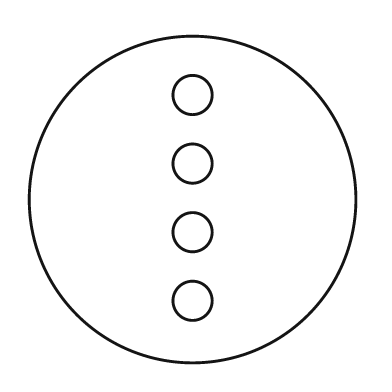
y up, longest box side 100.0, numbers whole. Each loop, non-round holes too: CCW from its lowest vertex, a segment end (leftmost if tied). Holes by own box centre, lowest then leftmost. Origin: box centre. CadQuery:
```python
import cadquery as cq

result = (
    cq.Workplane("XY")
    .moveTo(0.0, 0.0)
    .circle(50.0)
    .moveTo(0.0, -31.0)
    .circle(6.0)
    .moveTo(0.0, -10.0)
    .circle(6.0)
    .moveTo(0.0, 11.0)
    .circle(6.0)
    .moveTo(0.0, 32.0)
    .circle(6.0)
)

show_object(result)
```